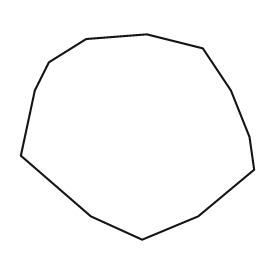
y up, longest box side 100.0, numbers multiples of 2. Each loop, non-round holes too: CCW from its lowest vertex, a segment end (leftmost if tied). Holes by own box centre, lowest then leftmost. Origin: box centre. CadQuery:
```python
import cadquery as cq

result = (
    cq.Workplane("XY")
    .moveTo(2.0, -44.0)
    .lineTo(26.0, -34.0)
    .lineTo(50.0, -14.0)
    .lineTo(48.0, 0.0)
    .lineTo(40.0, 20.0)
    .lineTo(28.0, 38.0)
    .lineTo(4.0, 44.0)
    .lineTo(-22.0, 42.0)
    .lineTo(-38.0, 32.0)
    .lineTo(-44.0, 20.0)
    .lineTo(-50.0, -8.0)
    .lineTo(-20.0, -34.0)
    .close()
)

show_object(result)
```